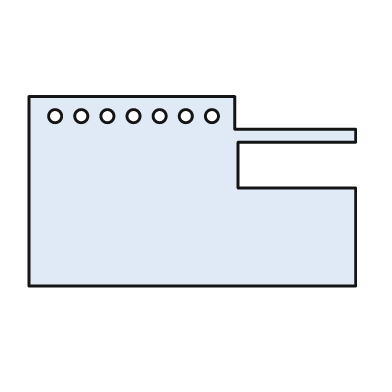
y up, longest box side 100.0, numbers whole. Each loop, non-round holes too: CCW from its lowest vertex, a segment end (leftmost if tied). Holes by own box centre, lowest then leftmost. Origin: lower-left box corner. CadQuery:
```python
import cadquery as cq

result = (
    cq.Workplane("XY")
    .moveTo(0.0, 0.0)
    .lineTo(100.0, 0.0)
    .lineTo(100.0, 30.0)
    .lineTo(64.0, 30.0)
    .lineTo(64.0, 44.0)
    .lineTo(100.0, 44.0)
    .lineTo(100.0, 48.0)
    .lineTo(63.0, 48.0)
    .lineTo(63.0, 58.0)
    .lineTo(0.0, 58.0)
    .close()
    .moveTo(8.0, 52.0)
    .circle(2.0)
    .moveTo(16.0, 52.0)
    .circle(2.0)
    .moveTo(24.0, 52.0)
    .circle(2.0)
    .moveTo(32.0, 52.0)
    .circle(2.0)
    .moveTo(40.0, 52.0)
    .circle(2.0)
    .moveTo(48.0, 52.0)
    .circle(2.0)
    .moveTo(56.0, 52.0)
    .circle(2.0)
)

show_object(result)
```